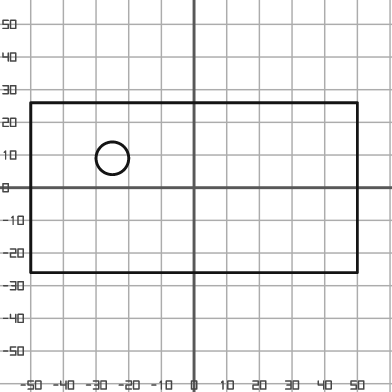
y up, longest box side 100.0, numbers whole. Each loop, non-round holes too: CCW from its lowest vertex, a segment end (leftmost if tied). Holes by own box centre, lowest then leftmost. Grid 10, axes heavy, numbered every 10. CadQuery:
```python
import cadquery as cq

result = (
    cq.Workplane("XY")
    .moveTo(-50.0, -26.0)
    .lineTo(50.0, -26.0)
    .lineTo(50.0, 26.0)
    .lineTo(-50.0, 26.0)
    .close()
    .moveTo(-25.0, 9.0)
    .circle(5.0)
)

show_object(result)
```